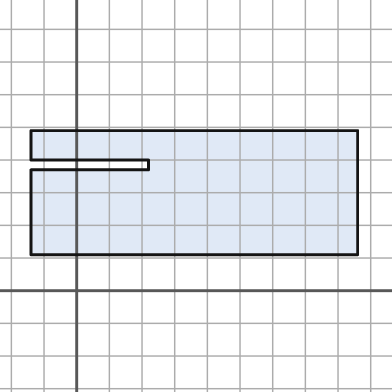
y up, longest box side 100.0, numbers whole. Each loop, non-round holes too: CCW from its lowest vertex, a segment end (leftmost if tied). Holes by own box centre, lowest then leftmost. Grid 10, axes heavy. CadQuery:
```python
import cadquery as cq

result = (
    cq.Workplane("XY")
    .moveTo(-14.0, 11.0)
    .lineTo(86.0, 11.0)
    .lineTo(86.0, 49.0)
    .lineTo(-14.0, 49.0)
    .lineTo(-14.0, 40.0)
    .lineTo(22.0, 40.0)
    .lineTo(22.0, 37.0)
    .lineTo(-14.0, 37.0)
    .close()
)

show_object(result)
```